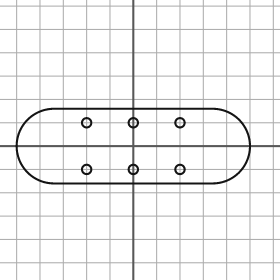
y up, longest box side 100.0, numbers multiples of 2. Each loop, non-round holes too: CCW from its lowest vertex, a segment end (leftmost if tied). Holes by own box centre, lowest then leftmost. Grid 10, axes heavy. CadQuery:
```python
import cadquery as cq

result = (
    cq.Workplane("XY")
    .moveTo(-34.0, -16.0)
    .lineTo(34.0, -16.0)
    .threePointArc((50.0, 0.0), (34.0, 16.0))
    .lineTo(-34.0, 16.0)
    .threePointArc((-50.0, 0.0), (-34.0, -16.0))
    .close()
    .moveTo(-20.0, -10.0)
    .circle(2.0)
    .moveTo(0.0, -10.0)
    .circle(2.0)
    .moveTo(20.0, -10.0)
    .circle(2.0)
    .moveTo(-20.0, 10.0)
    .circle(2.0)
    .moveTo(0.0, 10.0)
    .circle(2.0)
    .moveTo(20.0, 10.0)
    .circle(2.0)
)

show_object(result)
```